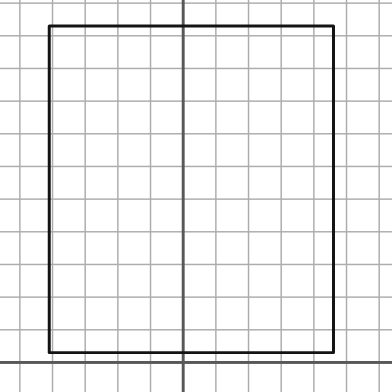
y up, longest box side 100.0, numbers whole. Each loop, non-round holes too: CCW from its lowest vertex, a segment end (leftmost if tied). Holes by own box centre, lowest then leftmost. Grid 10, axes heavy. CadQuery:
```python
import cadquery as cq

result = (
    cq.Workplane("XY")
    .moveTo(-41.0, 3.0)
    .lineTo(46.0, 3.0)
    .lineTo(46.0, 103.0)
    .lineTo(-41.0, 103.0)
    .close()
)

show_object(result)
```